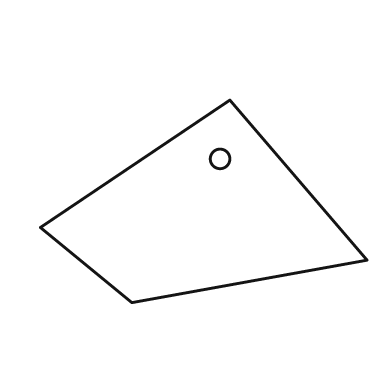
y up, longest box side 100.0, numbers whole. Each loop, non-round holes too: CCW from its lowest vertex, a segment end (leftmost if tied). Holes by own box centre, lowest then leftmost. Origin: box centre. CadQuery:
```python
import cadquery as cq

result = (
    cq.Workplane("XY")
    .moveTo(-22.0, -31.0)
    .lineTo(50.0, -18.0)
    .lineTo(8.0, 31.0)
    .lineTo(-50.0, -8.0)
    .close()
    .moveTo(5.0, 13.0)
    .circle(3.0)
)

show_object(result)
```